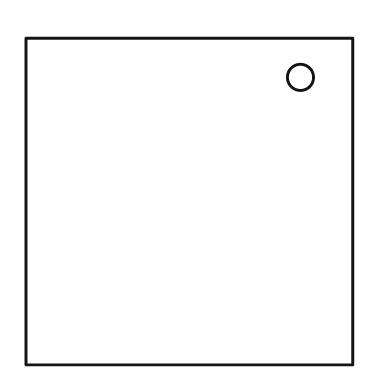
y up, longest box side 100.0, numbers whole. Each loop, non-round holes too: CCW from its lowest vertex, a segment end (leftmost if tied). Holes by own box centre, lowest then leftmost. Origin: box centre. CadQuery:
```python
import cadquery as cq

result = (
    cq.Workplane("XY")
    .moveTo(-50.0, -50.0)
    .lineTo(50.0, -50.0)
    .lineTo(50.0, 50.0)
    .lineTo(-50.0, 50.0)
    .close()
    .moveTo(34.0, 38.0)
    .circle(4.0)
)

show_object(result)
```